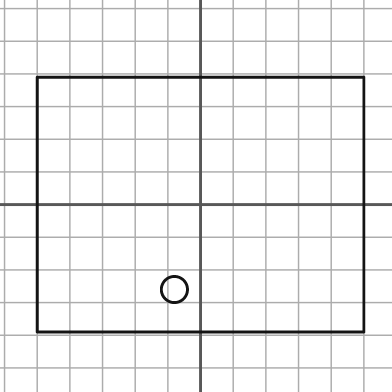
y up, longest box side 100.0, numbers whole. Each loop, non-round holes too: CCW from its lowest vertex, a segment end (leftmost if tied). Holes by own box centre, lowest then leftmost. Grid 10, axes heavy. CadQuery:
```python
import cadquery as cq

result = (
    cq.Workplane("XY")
    .moveTo(-50.0, -39.0)
    .lineTo(50.0, -39.0)
    .lineTo(50.0, 39.0)
    .lineTo(-50.0, 39.0)
    .close()
    .moveTo(-8.0, -26.0)
    .circle(4.0)
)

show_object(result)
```